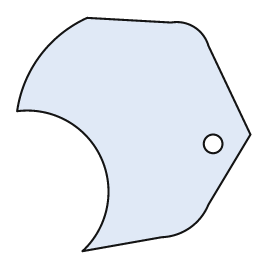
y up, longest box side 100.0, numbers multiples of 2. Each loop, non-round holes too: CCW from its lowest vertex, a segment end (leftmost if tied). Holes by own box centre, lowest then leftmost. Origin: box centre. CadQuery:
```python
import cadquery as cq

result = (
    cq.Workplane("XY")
    .moveTo(-22.0, -50.0)
    .lineTo(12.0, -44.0)
    .threePointArc((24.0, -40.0), (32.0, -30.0))
    .lineTo(50.0, 0.0)
    .lineTo(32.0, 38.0)
    .threePointArc((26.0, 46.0), (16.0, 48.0))
    .lineTo(-20.0, 50.0)
    .threePointArc((-40.0, 34.0), (-50.0, 10.0))
    .threePointArc((-14.0, -10.0), (-22.0, -50.0))
    .close()
    .moveTo(34.0, -4.0)
    .circle(4.0)
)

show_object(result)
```